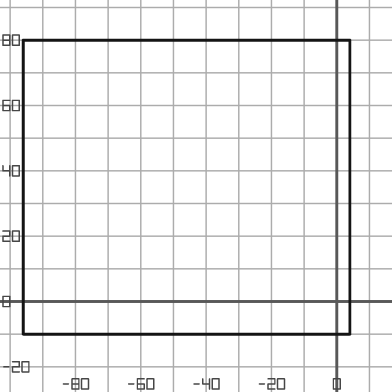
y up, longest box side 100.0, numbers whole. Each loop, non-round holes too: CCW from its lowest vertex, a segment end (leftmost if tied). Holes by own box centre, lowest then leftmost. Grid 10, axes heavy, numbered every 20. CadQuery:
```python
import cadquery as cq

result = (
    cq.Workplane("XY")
    .moveTo(-96.0, -10.0)
    .lineTo(4.0, -10.0)
    .lineTo(4.0, 80.0)
    .lineTo(-96.0, 80.0)
    .close()
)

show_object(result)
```